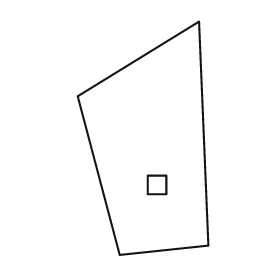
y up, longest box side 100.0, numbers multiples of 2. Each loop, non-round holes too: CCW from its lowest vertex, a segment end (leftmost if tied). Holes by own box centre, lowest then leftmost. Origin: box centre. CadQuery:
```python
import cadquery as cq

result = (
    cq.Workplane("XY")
    .moveTo(-10.0, -50.0)
    .lineTo(28.0, -46.0)
    .lineTo(24.0, 50.0)
    .lineTo(-28.0, 18.0)
    .close()
    .moveTo(2.0, -24.0)
    .lineTo(10.0, -24.0)
    .lineTo(10.0, -16.0)
    .lineTo(2.0, -16.0)
    .close()
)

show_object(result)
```